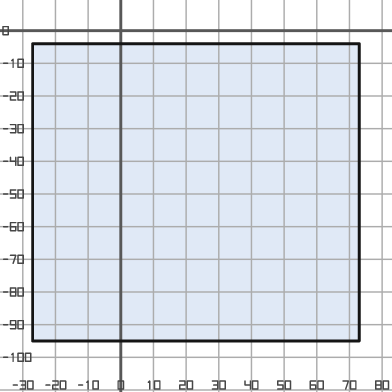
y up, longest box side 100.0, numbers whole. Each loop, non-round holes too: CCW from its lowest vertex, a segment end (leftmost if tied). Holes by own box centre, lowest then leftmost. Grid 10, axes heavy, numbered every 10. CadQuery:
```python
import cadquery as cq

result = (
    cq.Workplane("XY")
    .moveTo(-27.0, -95.0)
    .lineTo(73.0, -95.0)
    .lineTo(73.0, -4.0)
    .lineTo(-27.0, -4.0)
    .close()
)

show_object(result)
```